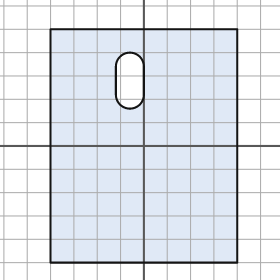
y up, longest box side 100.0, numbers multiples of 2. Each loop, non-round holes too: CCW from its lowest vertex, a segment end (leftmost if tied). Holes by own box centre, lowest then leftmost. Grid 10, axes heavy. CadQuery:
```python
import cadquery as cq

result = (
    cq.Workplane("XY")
    .moveTo(-40.0, -50.0)
    .lineTo(40.0, -50.0)
    .lineTo(40.0, 50.0)
    .lineTo(-40.0, 50.0)
    .close()
    .moveTo(-12.0, 22.0)
    .threePointArc((-6.0, 16.0), (0.0, 22.0))
    .lineTo(0.0, 34.0)
    .threePointArc((-6.0, 40.0), (-12.0, 34.0))
    .close()
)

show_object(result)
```